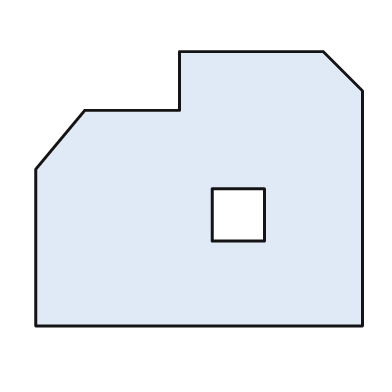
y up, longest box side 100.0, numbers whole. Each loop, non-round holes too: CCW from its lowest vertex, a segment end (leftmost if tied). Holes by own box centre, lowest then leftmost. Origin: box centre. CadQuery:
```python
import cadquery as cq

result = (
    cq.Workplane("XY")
    .moveTo(-50.0, -42.0)
    .lineTo(50.0, -42.0)
    .lineTo(50.0, 30.0)
    .lineTo(38.0, 42.0)
    .lineTo(-6.0, 42.0)
    .lineTo(-6.0, 24.0)
    .lineTo(-35.0, 24.0)
    .lineTo(-50.0, 6.0)
    .close()
    .moveTo(4.0, -16.0)
    .lineTo(20.0, -16.0)
    .lineTo(20.0, 0.0)
    .lineTo(4.0, 0.0)
    .close()
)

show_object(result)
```